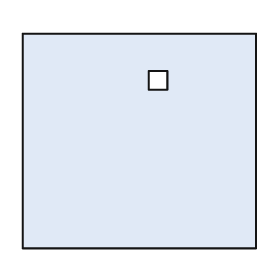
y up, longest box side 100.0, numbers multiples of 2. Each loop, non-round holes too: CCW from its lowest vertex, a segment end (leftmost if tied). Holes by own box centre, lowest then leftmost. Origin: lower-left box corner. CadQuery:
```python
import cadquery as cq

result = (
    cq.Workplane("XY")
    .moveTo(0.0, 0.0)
    .lineTo(100.0, 0.0)
    .lineTo(100.0, 92.0)
    .lineTo(0.0, 92.0)
    .close()
    .moveTo(54.0, 68.0)
    .lineTo(62.0, 68.0)
    .lineTo(62.0, 76.0)
    .lineTo(54.0, 76.0)
    .close()
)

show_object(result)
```